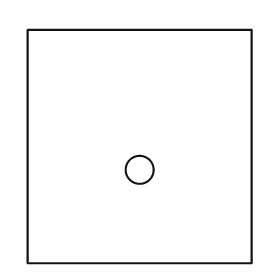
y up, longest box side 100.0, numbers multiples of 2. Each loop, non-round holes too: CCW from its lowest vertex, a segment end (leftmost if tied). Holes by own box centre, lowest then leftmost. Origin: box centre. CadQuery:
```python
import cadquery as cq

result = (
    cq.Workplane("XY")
    .moveTo(-48.0, -50.0)
    .lineTo(48.0, -50.0)
    .lineTo(48.0, 50.0)
    .lineTo(-48.0, 50.0)
    .close()
    .moveTo(0.0, -10.0)
    .circle(6.0)
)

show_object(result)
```